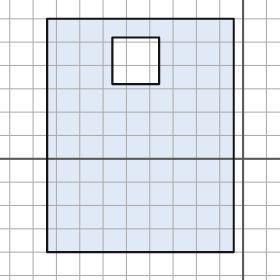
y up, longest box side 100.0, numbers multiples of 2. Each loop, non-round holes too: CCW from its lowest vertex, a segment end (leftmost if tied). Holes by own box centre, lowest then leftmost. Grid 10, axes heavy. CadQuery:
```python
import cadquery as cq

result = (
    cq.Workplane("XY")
    .moveTo(-84.0, -40.0)
    .lineTo(-4.0, -40.0)
    .lineTo(-4.0, 60.0)
    .lineTo(-84.0, 60.0)
    .close()
    .moveTo(-56.0, 32.0)
    .lineTo(-36.0, 32.0)
    .lineTo(-36.0, 52.0)
    .lineTo(-56.0, 52.0)
    .close()
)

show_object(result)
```